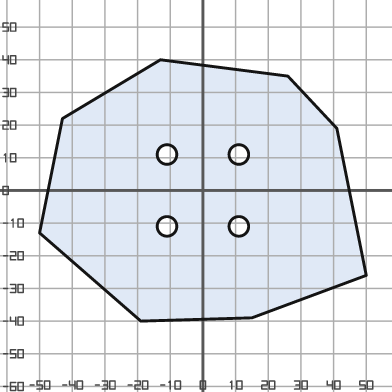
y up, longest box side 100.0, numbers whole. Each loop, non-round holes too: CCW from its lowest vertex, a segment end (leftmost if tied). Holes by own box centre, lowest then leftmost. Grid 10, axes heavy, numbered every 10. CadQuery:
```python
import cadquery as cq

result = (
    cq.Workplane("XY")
    .moveTo(-19.0, -40.0)
    .lineTo(15.0, -39.0)
    .lineTo(50.0, -26.0)
    .lineTo(41.0, 19.0)
    .lineTo(26.0, 35.0)
    .lineTo(-13.0, 40.0)
    .lineTo(-43.0, 22.0)
    .lineTo(-50.0, -13.0)
    .close()
    .moveTo(-11.0, -11.0)
    .circle(3.0)
    .moveTo(11.0, -11.0)
    .circle(3.0)
    .moveTo(-11.0, 11.0)
    .circle(3.0)
    .moveTo(11.0, 11.0)
    .circle(3.0)
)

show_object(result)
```